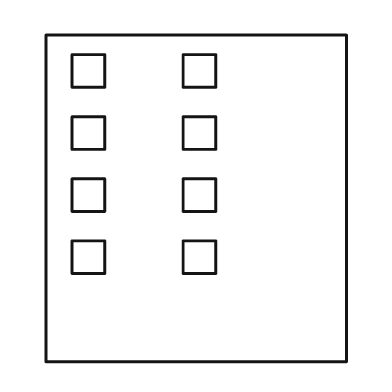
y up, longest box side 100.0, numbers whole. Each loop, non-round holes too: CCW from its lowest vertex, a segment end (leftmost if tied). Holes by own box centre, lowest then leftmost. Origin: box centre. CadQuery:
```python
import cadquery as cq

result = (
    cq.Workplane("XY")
    .moveTo(-46.0, -50.0)
    .lineTo(46.0, -50.0)
    .lineTo(46.0, 50.0)
    .lineTo(-46.0, 50.0)
    .close()
    .moveTo(-38.0, -23.0)
    .lineTo(-28.0, -23.0)
    .lineTo(-28.0, -13.0)
    .lineTo(-38.0, -13.0)
    .close()
    .moveTo(-4.0, -23.0)
    .lineTo(6.0, -23.0)
    .lineTo(6.0, -13.0)
    .lineTo(-4.0, -13.0)
    .close()
    .moveTo(-38.0, -4.0)
    .lineTo(-28.0, -4.0)
    .lineTo(-28.0, 6.0)
    .lineTo(-38.0, 6.0)
    .close()
    .moveTo(-4.0, -4.0)
    .lineTo(6.0, -4.0)
    .lineTo(6.0, 6.0)
    .lineTo(-4.0, 6.0)
    .close()
    .moveTo(-38.0, 15.0)
    .lineTo(-28.0, 15.0)
    .lineTo(-28.0, 25.0)
    .lineTo(-38.0, 25.0)
    .close()
    .moveTo(-4.0, 15.0)
    .lineTo(6.0, 15.0)
    .lineTo(6.0, 25.0)
    .lineTo(-4.0, 25.0)
    .close()
    .moveTo(-38.0, 34.0)
    .lineTo(-28.0, 34.0)
    .lineTo(-28.0, 44.0)
    .lineTo(-38.0, 44.0)
    .close()
    .moveTo(-4.0, 34.0)
    .lineTo(6.0, 34.0)
    .lineTo(6.0, 44.0)
    .lineTo(-4.0, 44.0)
    .close()
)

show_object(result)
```